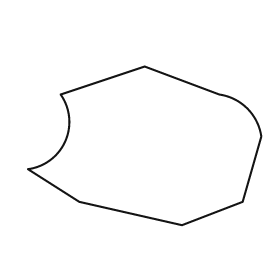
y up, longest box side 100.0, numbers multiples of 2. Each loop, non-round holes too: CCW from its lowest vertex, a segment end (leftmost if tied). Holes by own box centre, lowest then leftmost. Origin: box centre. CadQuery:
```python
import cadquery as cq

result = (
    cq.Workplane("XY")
    .moveTo(16.0, -34.0)
    .lineTo(42.0, -24.0)
    .lineTo(50.0, 4.0)
    .threePointArc((44.0, 16.0), (32.0, 22.0))
    .lineTo(0.0, 34.0)
    .lineTo(-36.0, 22.0)
    .threePointArc((-34.0, 2.0), (-50.0, -10.0))
    .lineTo(-28.0, -24.0)
    .close()
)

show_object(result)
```